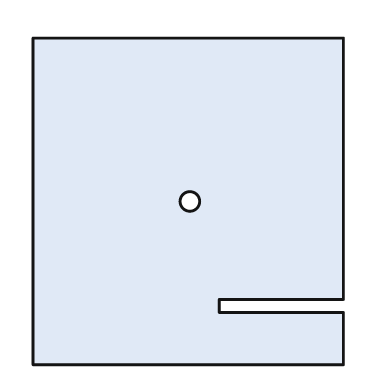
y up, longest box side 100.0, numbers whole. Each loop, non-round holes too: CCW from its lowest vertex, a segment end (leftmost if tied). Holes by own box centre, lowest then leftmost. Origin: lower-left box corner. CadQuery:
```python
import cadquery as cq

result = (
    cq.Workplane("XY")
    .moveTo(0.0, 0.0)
    .lineTo(95.0, 0.0)
    .lineTo(95.0, 16.0)
    .lineTo(57.0, 16.0)
    .lineTo(57.0, 20.0)
    .lineTo(95.0, 20.0)
    .lineTo(95.0, 100.0)
    .lineTo(0.0, 100.0)
    .close()
    .moveTo(48.0, 50.0)
    .circle(3.0)
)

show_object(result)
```